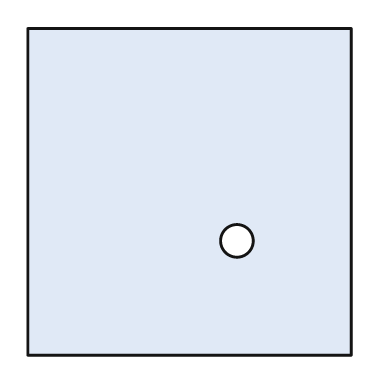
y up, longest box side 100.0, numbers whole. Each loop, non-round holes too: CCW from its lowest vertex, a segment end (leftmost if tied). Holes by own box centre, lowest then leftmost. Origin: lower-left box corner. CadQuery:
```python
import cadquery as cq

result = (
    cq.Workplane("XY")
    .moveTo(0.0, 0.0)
    .lineTo(99.0, 0.0)
    .lineTo(99.0, 100.0)
    .lineTo(0.0, 100.0)
    .close()
    .moveTo(64.0, 35.0)
    .circle(5.0)
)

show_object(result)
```